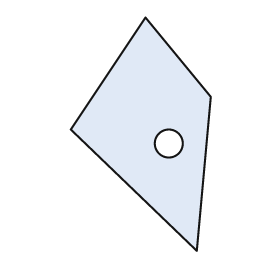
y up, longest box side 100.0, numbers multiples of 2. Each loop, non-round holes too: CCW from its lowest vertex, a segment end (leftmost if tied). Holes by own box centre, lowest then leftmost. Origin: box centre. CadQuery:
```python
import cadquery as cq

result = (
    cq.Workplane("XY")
    .moveTo(24.0, -50.0)
    .lineTo(30.0, 16.0)
    .lineTo(2.0, 50.0)
    .lineTo(-30.0, 2.0)
    .close()
    .moveTo(12.0, -4.0)
    .circle(6.0)
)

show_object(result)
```